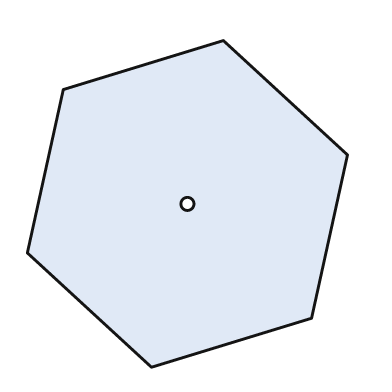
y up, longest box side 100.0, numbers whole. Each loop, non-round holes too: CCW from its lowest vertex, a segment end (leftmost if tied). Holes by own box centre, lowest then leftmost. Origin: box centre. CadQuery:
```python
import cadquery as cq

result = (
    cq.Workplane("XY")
    .moveTo(-11.0, -50.0)
    .lineTo(38.0, -35.0)
    .lineTo(49.0, 15.0)
    .lineTo(11.0, 50.0)
    .lineTo(-38.0, 35.0)
    .lineTo(-49.0, -15.0)
    .close()
    .moveTo(0.0, 0.0)
    .circle(2.0)
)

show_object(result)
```